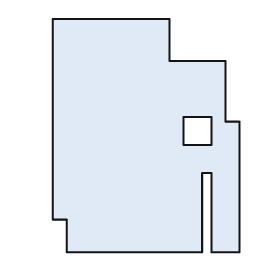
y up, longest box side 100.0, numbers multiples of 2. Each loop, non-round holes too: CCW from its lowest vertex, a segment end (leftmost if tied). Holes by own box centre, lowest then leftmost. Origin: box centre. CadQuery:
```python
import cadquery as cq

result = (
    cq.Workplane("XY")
    .moveTo(-34.0, -50.0)
    .lineTo(24.0, -50.0)
    .lineTo(24.0, -16.0)
    .lineTo(28.0, -16.0)
    .lineTo(28.0, -50.0)
    .lineTo(40.0, -50.0)
    .lineTo(40.0, 6.0)
    .lineTo(34.0, 6.0)
    .lineTo(34.0, 32.0)
    .lineTo(10.0, 32.0)
    .lineTo(10.0, 50.0)
    .lineTo(-40.0, 50.0)
    .lineTo(-40.0, -36.0)
    .lineTo(-34.0, -36.0)
    .close()
    .moveTo(16.0, -4.0)
    .lineTo(28.0, -4.0)
    .lineTo(28.0, 8.0)
    .lineTo(16.0, 8.0)
    .close()
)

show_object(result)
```